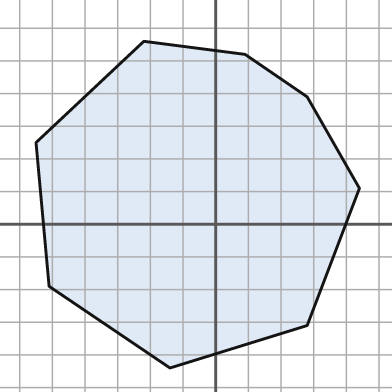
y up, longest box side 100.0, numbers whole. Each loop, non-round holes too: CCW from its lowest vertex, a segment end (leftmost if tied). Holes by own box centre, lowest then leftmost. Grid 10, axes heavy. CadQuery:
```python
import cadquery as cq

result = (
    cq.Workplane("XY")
    .moveTo(-14.0, -44.0)
    .lineTo(28.0, -31.0)
    .lineTo(44.0, 11.0)
    .lineTo(28.0, 39.0)
    .lineTo(9.0, 52.0)
    .lineTo(-22.0, 56.0)
    .lineTo(-55.0, 25.0)
    .lineTo(-51.0, -19.0)
    .close()
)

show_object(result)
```